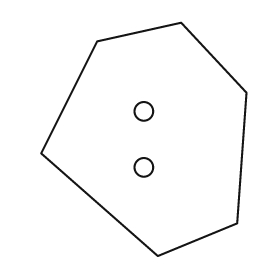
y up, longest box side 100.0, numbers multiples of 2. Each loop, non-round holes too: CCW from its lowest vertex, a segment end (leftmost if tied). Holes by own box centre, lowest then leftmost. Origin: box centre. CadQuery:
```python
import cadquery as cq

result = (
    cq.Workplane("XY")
    .moveTo(6.0, -50.0)
    .lineTo(40.0, -36.0)
    .lineTo(44.0, 20.0)
    .lineTo(16.0, 50.0)
    .lineTo(-20.0, 42.0)
    .lineTo(-44.0, -6.0)
    .close()
    .moveTo(0.0, -12.0)
    .circle(4.0)
    .moveTo(0.0, 12.0)
    .circle(4.0)
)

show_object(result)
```